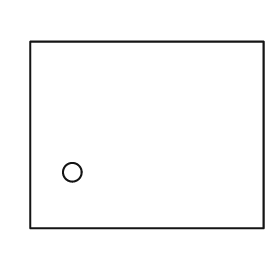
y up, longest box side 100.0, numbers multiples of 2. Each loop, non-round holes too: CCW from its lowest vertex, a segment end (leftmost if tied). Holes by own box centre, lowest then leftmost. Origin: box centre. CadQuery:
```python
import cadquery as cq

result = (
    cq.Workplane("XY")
    .moveTo(-50.0, -40.0)
    .lineTo(50.0, -40.0)
    .lineTo(50.0, 40.0)
    .lineTo(-50.0, 40.0)
    .close()
    .moveTo(-32.0, -16.0)
    .circle(4.0)
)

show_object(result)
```